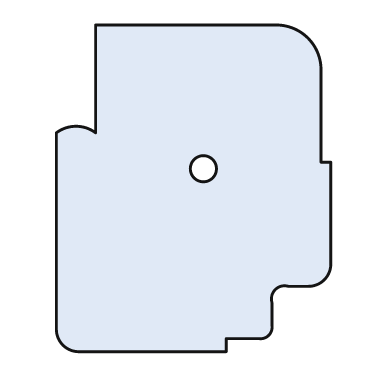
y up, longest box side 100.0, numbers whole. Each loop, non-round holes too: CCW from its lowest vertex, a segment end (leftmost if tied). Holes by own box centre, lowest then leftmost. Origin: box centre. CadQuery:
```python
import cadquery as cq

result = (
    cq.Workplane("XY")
    .moveTo(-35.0, -50.0)
    .lineTo(10.0, -50.0)
    .lineTo(10.0, -46.0)
    .lineTo(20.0, -46.0)
    .threePointArc((23.0, -45.0), (24.0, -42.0))
    .lineTo(24.0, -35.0)
    .threePointArc((25.0, -31.0), (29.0, -30.0))
    .lineTo(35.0, -30.0)
    .threePointArc((40.0, -28.0), (42.0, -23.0))
    .lineTo(42.0, 8.0)
    .lineTo(39.0, 8.0)
    .lineTo(39.0, 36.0)
    .threePointArc((35.0, 46.0), (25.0, 50.0))
    .lineTo(-30.0, 50.0)
    .lineTo(-30.0, 17.0)
    .threePointArc((-36.0, 19.0), (-42.0, 17.0))
    .lineTo(-42.0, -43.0)
    .threePointArc((-40.0, -48.0), (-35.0, -50.0))
    .close()
    .moveTo(3.0, 6.0)
    .circle(4.0)
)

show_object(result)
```